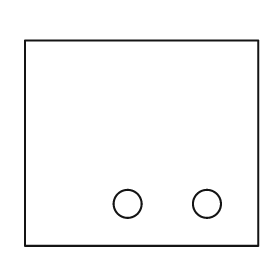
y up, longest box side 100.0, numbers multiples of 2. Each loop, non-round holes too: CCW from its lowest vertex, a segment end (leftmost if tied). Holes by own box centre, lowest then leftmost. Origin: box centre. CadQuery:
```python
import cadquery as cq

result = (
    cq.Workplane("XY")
    .moveTo(-50.0, -44.0)
    .lineTo(50.0, -44.0)
    .lineTo(50.0, 44.0)
    .lineTo(-50.0, 44.0)
    .close()
    .moveTo(-6.0, -26.0)
    .circle(6.0)
    .moveTo(28.0, -26.0)
    .circle(6.0)
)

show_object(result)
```